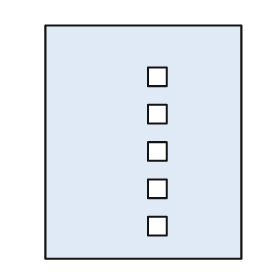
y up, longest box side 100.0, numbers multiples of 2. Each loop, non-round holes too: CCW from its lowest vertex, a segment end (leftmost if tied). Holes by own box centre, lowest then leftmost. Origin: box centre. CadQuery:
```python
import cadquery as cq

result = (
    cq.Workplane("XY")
    .moveTo(-42.0, -50.0)
    .lineTo(42.0, -50.0)
    .lineTo(42.0, 50.0)
    .lineTo(-42.0, 50.0)
    .close()
    .moveTo(2.0, -40.0)
    .lineTo(10.0, -40.0)
    .lineTo(10.0, -32.0)
    .lineTo(2.0, -32.0)
    .close()
    .moveTo(2.0, -24.0)
    .lineTo(10.0, -24.0)
    .lineTo(10.0, -16.0)
    .lineTo(2.0, -16.0)
    .close()
    .moveTo(2.0, -8.0)
    .lineTo(10.0, -8.0)
    .lineTo(10.0, 0.0)
    .lineTo(2.0, 0.0)
    .close()
    .moveTo(2.0, 8.0)
    .lineTo(10.0, 8.0)
    .lineTo(10.0, 16.0)
    .lineTo(2.0, 16.0)
    .close()
    .moveTo(2.0, 24.0)
    .lineTo(10.0, 24.0)
    .lineTo(10.0, 32.0)
    .lineTo(2.0, 32.0)
    .close()
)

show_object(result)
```